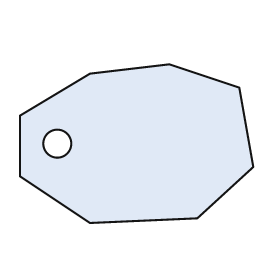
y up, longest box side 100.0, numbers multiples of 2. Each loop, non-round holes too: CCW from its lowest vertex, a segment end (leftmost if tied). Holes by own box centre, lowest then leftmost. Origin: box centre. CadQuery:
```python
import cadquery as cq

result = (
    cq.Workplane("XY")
    .moveTo(-20.0, -34.0)
    .lineTo(26.0, -32.0)
    .lineTo(50.0, -10.0)
    .lineTo(44.0, 24.0)
    .lineTo(14.0, 34.0)
    .lineTo(-20.0, 30.0)
    .lineTo(-50.0, 12.0)
    .lineTo(-50.0, -14.0)
    .close()
    .moveTo(-34.0, 0.0)
    .circle(6.0)
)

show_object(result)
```